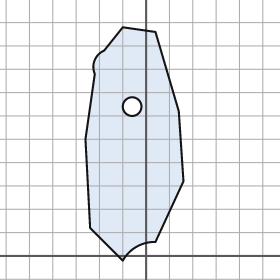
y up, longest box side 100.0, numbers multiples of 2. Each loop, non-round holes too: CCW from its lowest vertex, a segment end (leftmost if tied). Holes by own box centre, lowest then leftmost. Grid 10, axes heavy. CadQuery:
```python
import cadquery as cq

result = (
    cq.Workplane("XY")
    .moveTo(-10.0, -2.0)
    .threePointArc((-4.0, 4.0), (4.0, 6.0))
    .lineTo(16.0, 32.0)
    .lineTo(14.0, 62.0)
    .lineTo(4.0, 96.0)
    .lineTo(-10.0, 98.0)
    .lineTo(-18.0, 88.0)
    .threePointArc((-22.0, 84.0), (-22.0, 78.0))
    .lineTo(-26.0, 50.0)
    .lineTo(-24.0, 12.0)
    .close()
    .moveTo(-6.0, 64.0)
    .circle(4.0)
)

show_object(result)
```